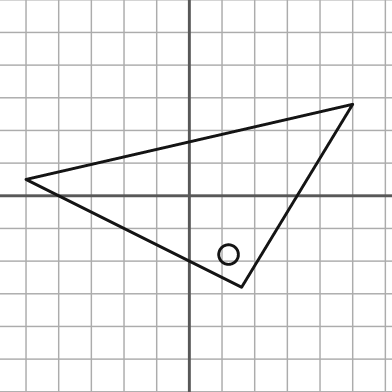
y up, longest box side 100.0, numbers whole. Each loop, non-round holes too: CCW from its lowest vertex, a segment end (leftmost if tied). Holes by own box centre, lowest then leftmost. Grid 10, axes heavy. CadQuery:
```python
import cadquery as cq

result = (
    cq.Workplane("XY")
    .moveTo(16.0, -28.0)
    .lineTo(50.0, 28.0)
    .lineTo(-50.0, 5.0)
    .close()
    .moveTo(12.0, -18.0)
    .circle(3.0)
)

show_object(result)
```